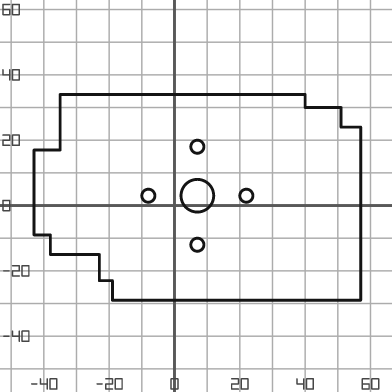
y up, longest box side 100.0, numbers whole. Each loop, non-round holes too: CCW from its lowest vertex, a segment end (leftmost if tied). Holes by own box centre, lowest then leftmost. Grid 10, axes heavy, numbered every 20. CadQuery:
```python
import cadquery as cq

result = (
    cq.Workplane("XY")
    .moveTo(-19.0, -29.0)
    .lineTo(57.0, -29.0)
    .lineTo(57.0, 24.0)
    .lineTo(51.0, 24.0)
    .lineTo(51.0, 30.0)
    .lineTo(40.0, 30.0)
    .lineTo(40.0, 34.0)
    .lineTo(-35.0, 34.0)
    .lineTo(-35.0, 17.0)
    .lineTo(-43.0, 17.0)
    .lineTo(-43.0, -9.0)
    .lineTo(-38.0, -9.0)
    .lineTo(-38.0, -15.0)
    .lineTo(-23.0, -15.0)
    .lineTo(-23.0, -23.0)
    .lineTo(-19.0, -23.0)
    .close()
    .moveTo(7.0, -12.0)
    .circle(2.0)
    .moveTo(-8.0, 3.0)
    .circle(2.0)
    .moveTo(7.0, 3.0)
    .circle(5.0)
    .moveTo(22.0, 3.0)
    .circle(2.0)
    .moveTo(7.0, 18.0)
    .circle(2.0)
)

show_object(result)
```